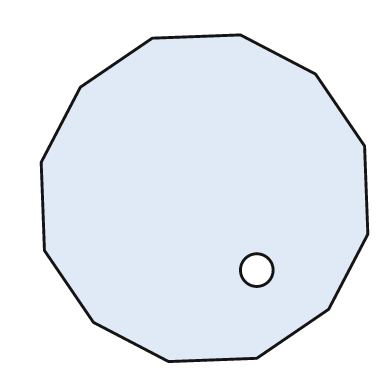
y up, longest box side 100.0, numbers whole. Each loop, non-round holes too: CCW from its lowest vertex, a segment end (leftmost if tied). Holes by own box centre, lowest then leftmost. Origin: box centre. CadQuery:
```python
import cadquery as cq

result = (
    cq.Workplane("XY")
    .moveTo(-11.0, -50.0)
    .lineTo(16.0, -49.0)
    .lineTo(38.0, -34.0)
    .lineTo(50.0, -11.0)
    .lineTo(49.0, 16.0)
    .lineTo(34.0, 38.0)
    .lineTo(11.0, 50.0)
    .lineTo(-16.0, 49.0)
    .lineTo(-38.0, 34.0)
    .lineTo(-50.0, 11.0)
    .lineTo(-49.0, -16.0)
    .lineTo(-34.0, -38.0)
    .close()
    .moveTo(16.0, -22.0)
    .circle(5.0)
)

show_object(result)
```